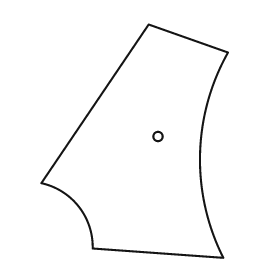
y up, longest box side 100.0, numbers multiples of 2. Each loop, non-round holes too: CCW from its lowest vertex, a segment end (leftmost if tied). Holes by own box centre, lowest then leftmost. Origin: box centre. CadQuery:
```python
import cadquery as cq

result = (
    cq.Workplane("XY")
    .moveTo(38.0, -50.0)
    .threePointArc((28.0, -6.0), (40.0, 38.0))
    .lineTo(6.0, 50.0)
    .lineTo(-40.0, -18.0)
    .threePointArc((-24.0, -28.0), (-18.0, -46.0))
    .close()
    .moveTo(10.0, 2.0)
    .circle(2.0)
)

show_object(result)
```